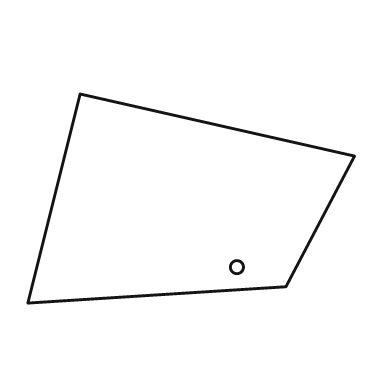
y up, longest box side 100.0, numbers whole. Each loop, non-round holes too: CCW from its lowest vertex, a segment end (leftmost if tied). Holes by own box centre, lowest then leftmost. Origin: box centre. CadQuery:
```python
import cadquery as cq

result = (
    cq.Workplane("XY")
    .moveTo(-50.0, -32.0)
    .lineTo(29.0, -27.0)
    .lineTo(50.0, 13.0)
    .lineTo(-34.0, 32.0)
    .close()
    .moveTo(14.0, -21.0)
    .circle(2.0)
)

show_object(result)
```